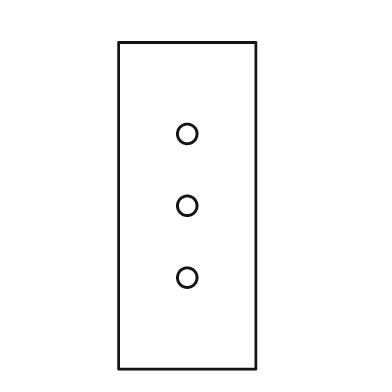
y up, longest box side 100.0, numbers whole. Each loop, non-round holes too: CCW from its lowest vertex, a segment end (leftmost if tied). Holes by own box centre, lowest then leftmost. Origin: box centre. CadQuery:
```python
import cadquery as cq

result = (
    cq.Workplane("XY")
    .moveTo(-21.0, -50.0)
    .lineTo(21.0, -50.0)
    .lineTo(21.0, 50.0)
    .lineTo(-21.0, 50.0)
    .close()
    .moveTo(0.0, -22.0)
    .circle(3.0)
    .moveTo(0.0, 0.0)
    .circle(3.0)
    .moveTo(0.0, 22.0)
    .circle(3.0)
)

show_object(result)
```